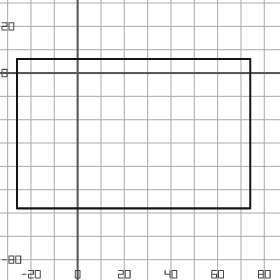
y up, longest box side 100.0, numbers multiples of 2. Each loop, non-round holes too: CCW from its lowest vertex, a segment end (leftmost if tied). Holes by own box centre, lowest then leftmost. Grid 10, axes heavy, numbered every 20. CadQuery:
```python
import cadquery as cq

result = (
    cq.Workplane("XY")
    .moveTo(-26.0, -58.0)
    .lineTo(74.0, -58.0)
    .lineTo(74.0, 6.0)
    .lineTo(-26.0, 6.0)
    .close()
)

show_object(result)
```